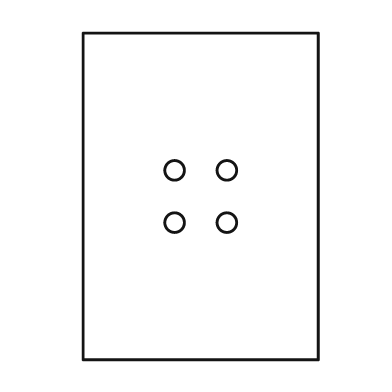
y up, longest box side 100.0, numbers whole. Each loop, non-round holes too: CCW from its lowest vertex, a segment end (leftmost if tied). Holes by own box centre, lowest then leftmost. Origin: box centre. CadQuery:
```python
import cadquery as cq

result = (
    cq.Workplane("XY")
    .moveTo(-36.0, -50.0)
    .lineTo(36.0, -50.0)
    .lineTo(36.0, 50.0)
    .lineTo(-36.0, 50.0)
    .close()
    .moveTo(-8.0, -8.0)
    .circle(3.0)
    .moveTo(8.0, -8.0)
    .circle(3.0)
    .moveTo(-8.0, 8.0)
    .circle(3.0)
    .moveTo(8.0, 8.0)
    .circle(3.0)
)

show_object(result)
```